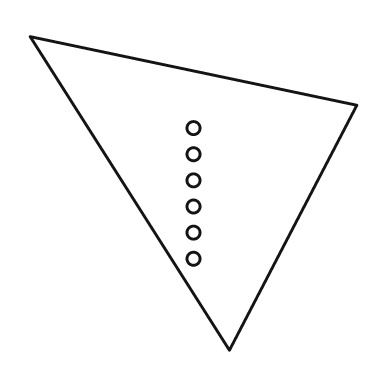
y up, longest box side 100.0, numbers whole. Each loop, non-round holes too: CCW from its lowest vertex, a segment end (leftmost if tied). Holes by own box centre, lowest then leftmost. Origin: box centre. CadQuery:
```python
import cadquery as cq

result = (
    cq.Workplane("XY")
    .moveTo(11.0, -48.0)
    .lineTo(50.0, 27.0)
    .lineTo(-50.0, 48.0)
    .close()
    .moveTo(0.0, -20.0)
    .circle(2.0)
    .moveTo(0.0, -12.0)
    .circle(2.0)
    .moveTo(0.0, -4.0)
    .circle(2.0)
    .moveTo(0.0, 4.0)
    .circle(2.0)
    .moveTo(0.0, 12.0)
    .circle(2.0)
    .moveTo(0.0, 20.0)
    .circle(2.0)
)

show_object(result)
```